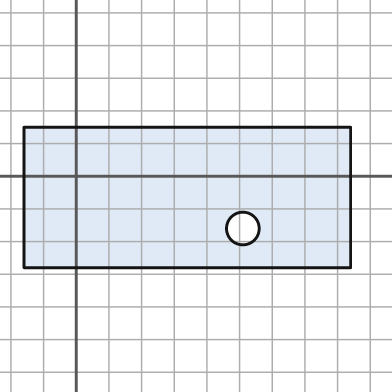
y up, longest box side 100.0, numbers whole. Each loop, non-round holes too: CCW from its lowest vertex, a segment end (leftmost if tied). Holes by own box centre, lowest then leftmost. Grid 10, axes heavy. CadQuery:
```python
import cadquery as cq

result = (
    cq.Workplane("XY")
    .moveTo(-16.0, -28.0)
    .lineTo(84.0, -28.0)
    .lineTo(84.0, 15.0)
    .lineTo(-16.0, 15.0)
    .close()
    .moveTo(51.0, -16.0)
    .circle(5.0)
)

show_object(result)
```